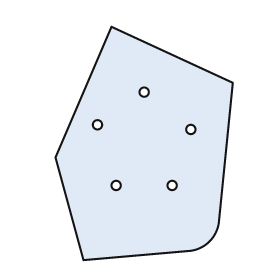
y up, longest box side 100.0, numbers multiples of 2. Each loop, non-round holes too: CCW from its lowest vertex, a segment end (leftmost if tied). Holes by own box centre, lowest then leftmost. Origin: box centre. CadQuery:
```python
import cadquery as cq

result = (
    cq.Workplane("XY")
    .moveTo(-26.0, -50.0)
    .lineTo(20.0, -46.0)
    .threePointArc((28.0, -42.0), (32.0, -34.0))
    .lineTo(38.0, 26.0)
    .lineTo(-14.0, 50.0)
    .lineTo(-38.0, -6.0)
    .close()
    .moveTo(-12.0, -18.0)
    .circle(2.0)
    .moveTo(12.0, -18.0)
    .circle(2.0)
    .moveTo(20.0, 6.0)
    .circle(2.0)
    .moveTo(-20.0, 8.0)
    .circle(2.0)
    .moveTo(0.0, 22.0)
    .circle(2.0)
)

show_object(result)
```